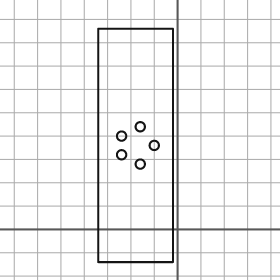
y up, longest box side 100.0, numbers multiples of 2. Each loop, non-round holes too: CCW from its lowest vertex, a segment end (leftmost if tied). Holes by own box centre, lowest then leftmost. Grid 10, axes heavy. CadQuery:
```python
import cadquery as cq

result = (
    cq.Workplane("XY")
    .moveTo(-34.0, -14.0)
    .lineTo(-2.0, -14.0)
    .lineTo(-2.0, 86.0)
    .lineTo(-34.0, 86.0)
    .close()
    .moveTo(-16.0, 28.0)
    .circle(2.0)
    .moveTo(-24.0, 32.0)
    .circle(2.0)
    .moveTo(-10.0, 36.0)
    .circle(2.0)
    .moveTo(-24.0, 40.0)
    .circle(2.0)
    .moveTo(-16.0, 44.0)
    .circle(2.0)
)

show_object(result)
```